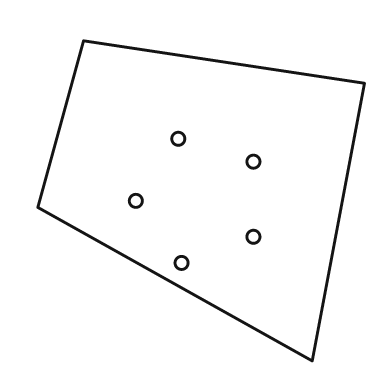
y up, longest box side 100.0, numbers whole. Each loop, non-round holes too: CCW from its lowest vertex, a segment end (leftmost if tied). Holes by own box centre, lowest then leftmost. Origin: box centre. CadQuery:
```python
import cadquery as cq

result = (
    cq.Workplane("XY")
    .moveTo(34.0, -49.0)
    .lineTo(50.0, 36.0)
    .lineTo(-36.0, 49.0)
    .lineTo(-50.0, -2.0)
    .close()
    .moveTo(-6.0, -19.0)
    .circle(2.0)
    .moveTo(16.0, -11.0)
    .circle(2.0)
    .moveTo(-20.0, 0.0)
    .circle(2.0)
    .moveTo(16.0, 12.0)
    .circle(2.0)
    .moveTo(-7.0, 19.0)
    .circle(2.0)
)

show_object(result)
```